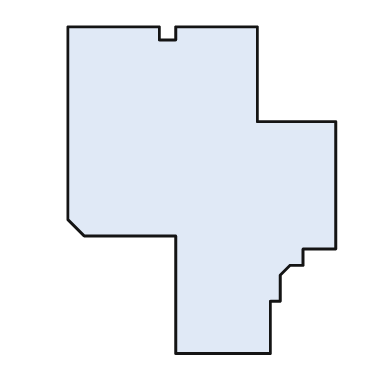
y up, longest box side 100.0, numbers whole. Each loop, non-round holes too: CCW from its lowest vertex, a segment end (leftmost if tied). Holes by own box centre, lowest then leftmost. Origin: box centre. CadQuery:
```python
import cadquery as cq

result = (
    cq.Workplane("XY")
    .moveTo(-8.0, -50.0)
    .lineTo(21.0, -50.0)
    .lineTo(21.0, -34.0)
    .lineTo(24.0, -34.0)
    .lineTo(24.0, -26.0)
    .lineTo(27.0, -23.0)
    .lineTo(31.0, -23.0)
    .lineTo(31.0, -18.0)
    .lineTo(41.0, -18.0)
    .lineTo(41.0, 21.0)
    .lineTo(17.0, 21.0)
    .lineTo(17.0, 50.0)
    .lineTo(-8.0, 50.0)
    .lineTo(-8.0, 46.0)
    .lineTo(-13.0, 46.0)
    .lineTo(-13.0, 50.0)
    .lineTo(-41.0, 50.0)
    .lineTo(-41.0, -9.0)
    .lineTo(-36.0, -14.0)
    .lineTo(-8.0, -14.0)
    .close()
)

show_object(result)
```